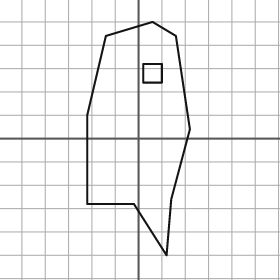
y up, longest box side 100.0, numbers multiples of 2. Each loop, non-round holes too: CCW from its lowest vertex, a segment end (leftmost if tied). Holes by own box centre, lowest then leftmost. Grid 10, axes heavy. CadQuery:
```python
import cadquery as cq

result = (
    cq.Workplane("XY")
    .moveTo(12.0, -50.0)
    .lineTo(14.0, -26.0)
    .lineTo(22.0, 4.0)
    .lineTo(16.0, 44.0)
    .lineTo(6.0, 50.0)
    .lineTo(-14.0, 44.0)
    .lineTo(-22.0, 10.0)
    .lineTo(-22.0, -28.0)
    .lineTo(-2.0, -28.0)
    .close()
    .moveTo(2.0, 24.0)
    .lineTo(10.0, 24.0)
    .lineTo(10.0, 32.0)
    .lineTo(2.0, 32.0)
    .close()
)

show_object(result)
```